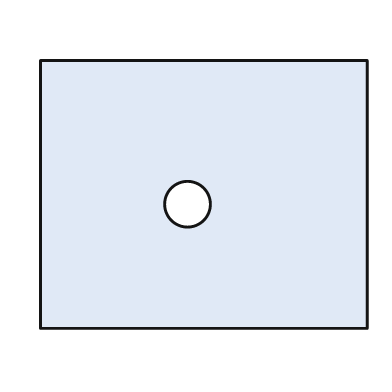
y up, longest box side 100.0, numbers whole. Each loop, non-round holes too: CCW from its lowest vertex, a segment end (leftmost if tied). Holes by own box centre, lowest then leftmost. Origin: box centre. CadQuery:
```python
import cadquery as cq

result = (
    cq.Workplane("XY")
    .moveTo(-50.0, -41.0)
    .lineTo(50.0, -41.0)
    .lineTo(50.0, 41.0)
    .lineTo(-50.0, 41.0)
    .close()
    .moveTo(-5.0, -3.0)
    .circle(7.0)
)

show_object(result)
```